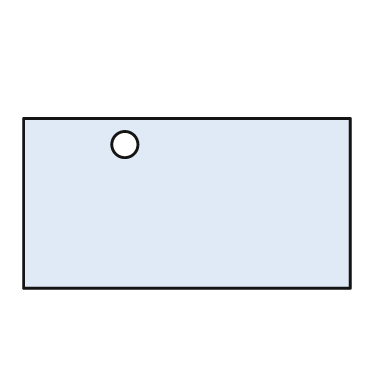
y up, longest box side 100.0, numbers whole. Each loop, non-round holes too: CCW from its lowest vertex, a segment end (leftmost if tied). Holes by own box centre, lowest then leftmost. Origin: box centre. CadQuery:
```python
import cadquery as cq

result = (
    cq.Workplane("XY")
    .moveTo(-50.0, -26.0)
    .lineTo(50.0, -26.0)
    .lineTo(50.0, 26.0)
    .lineTo(-50.0, 26.0)
    .close()
    .moveTo(-19.0, 18.0)
    .circle(4.0)
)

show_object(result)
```